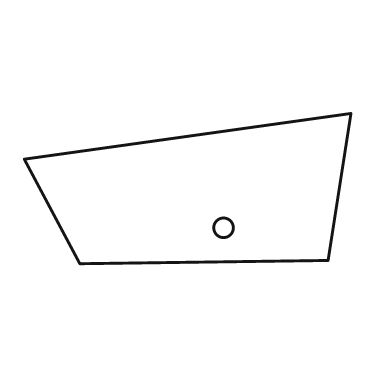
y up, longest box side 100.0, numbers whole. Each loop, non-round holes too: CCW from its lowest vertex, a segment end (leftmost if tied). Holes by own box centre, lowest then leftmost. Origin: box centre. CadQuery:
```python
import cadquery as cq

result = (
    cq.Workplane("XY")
    .moveTo(-33.0, -23.0)
    .lineTo(43.0, -22.0)
    .lineTo(50.0, 23.0)
    .lineTo(-50.0, 9.0)
    .close()
    .moveTo(11.0, -12.0)
    .circle(3.0)
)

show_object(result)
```